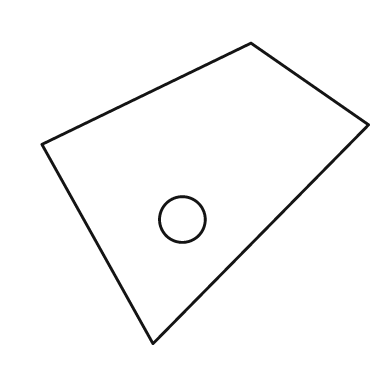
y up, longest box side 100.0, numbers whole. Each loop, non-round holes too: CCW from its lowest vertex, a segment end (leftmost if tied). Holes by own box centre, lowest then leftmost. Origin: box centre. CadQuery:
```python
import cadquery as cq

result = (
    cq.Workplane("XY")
    .moveTo(-16.0, -46.0)
    .lineTo(50.0, 21.0)
    .lineTo(14.0, 46.0)
    .lineTo(-50.0, 15.0)
    .close()
    .moveTo(-7.0, -8.0)
    .circle(7.0)
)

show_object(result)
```